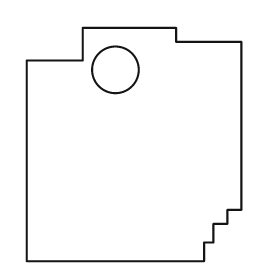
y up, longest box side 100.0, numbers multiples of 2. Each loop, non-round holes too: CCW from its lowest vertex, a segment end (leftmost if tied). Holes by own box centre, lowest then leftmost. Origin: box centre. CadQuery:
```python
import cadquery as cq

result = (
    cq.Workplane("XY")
    .moveTo(-46.0, -50.0)
    .lineTo(30.0, -50.0)
    .lineTo(30.0, -42.0)
    .lineTo(34.0, -42.0)
    .lineTo(34.0, -34.0)
    .lineTo(40.0, -34.0)
    .lineTo(40.0, -28.0)
    .lineTo(46.0, -28.0)
    .lineTo(46.0, 44.0)
    .lineTo(18.0, 44.0)
    .lineTo(18.0, 50.0)
    .lineTo(-22.0, 50.0)
    .lineTo(-22.0, 36.0)
    .lineTo(-46.0, 36.0)
    .close()
    .moveTo(-8.0, 32.0)
    .circle(10.0)
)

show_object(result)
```